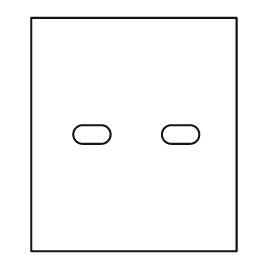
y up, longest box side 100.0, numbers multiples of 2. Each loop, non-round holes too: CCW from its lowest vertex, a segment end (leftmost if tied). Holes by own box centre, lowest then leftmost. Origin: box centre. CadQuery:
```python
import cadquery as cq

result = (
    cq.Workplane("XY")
    .moveTo(-44.0, -50.0)
    .lineTo(44.0, -50.0)
    .lineTo(44.0, 50.0)
    .lineTo(-44.0, 50.0)
    .close()
    .moveTo(-22.0, -4.0)
    .lineTo(-14.0, -4.0)
    .threePointArc((-10.0, 0.0), (-14.0, 4.0))
    .lineTo(-22.0, 4.0)
    .threePointArc((-26.0, 0.0), (-22.0, -4.0))
    .close()
    .moveTo(16.0, -4.0)
    .lineTo(24.0, -4.0)
    .threePointArc((28.0, 0.0), (24.0, 4.0))
    .lineTo(16.0, 4.0)
    .threePointArc((12.0, 0.0), (16.0, -4.0))
    .close()
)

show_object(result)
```